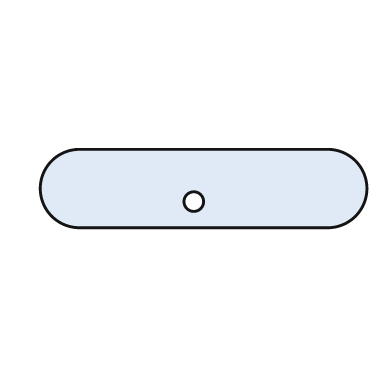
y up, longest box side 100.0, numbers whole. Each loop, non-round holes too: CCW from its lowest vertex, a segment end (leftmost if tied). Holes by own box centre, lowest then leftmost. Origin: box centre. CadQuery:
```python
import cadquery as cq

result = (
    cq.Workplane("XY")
    .moveTo(-38.0, -12.0)
    .lineTo(38.0, -12.0)
    .threePointArc((50.0, 0.0), (38.0, 12.0))
    .lineTo(-38.0, 12.0)
    .threePointArc((-50.0, 0.0), (-38.0, -12.0))
    .close()
    .moveTo(-3.0, -4.0)
    .circle(3.0)
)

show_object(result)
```